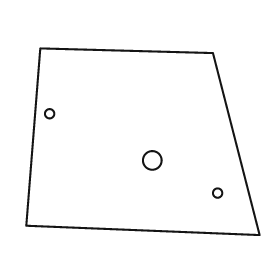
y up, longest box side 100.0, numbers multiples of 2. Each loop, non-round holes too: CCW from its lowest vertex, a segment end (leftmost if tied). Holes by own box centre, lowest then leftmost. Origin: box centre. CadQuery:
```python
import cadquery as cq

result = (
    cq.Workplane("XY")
    .moveTo(50.0, -40.0)
    .lineTo(30.0, 38.0)
    .lineTo(-44.0, 40.0)
    .lineTo(-50.0, -36.0)
    .close()
    .moveTo(32.0, -22.0)
    .circle(2.0)
    .moveTo(4.0, -8.0)
    .circle(4.0)
    .moveTo(-40.0, 12.0)
    .circle(2.0)
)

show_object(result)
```